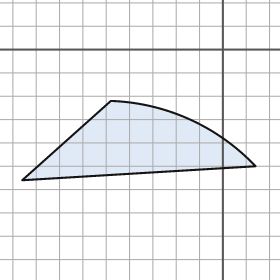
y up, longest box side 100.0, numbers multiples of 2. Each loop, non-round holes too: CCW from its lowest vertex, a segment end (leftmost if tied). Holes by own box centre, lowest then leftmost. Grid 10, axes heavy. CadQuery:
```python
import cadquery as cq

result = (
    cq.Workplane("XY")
    .moveTo(-86.0, -56.0)
    .lineTo(14.0, -50.0)
    .threePointArc((-14.0, -30.0), (-48.0, -22.0))
    .close()
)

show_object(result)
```